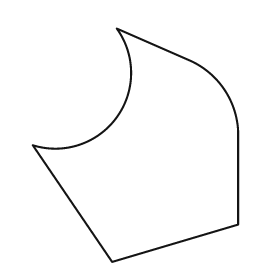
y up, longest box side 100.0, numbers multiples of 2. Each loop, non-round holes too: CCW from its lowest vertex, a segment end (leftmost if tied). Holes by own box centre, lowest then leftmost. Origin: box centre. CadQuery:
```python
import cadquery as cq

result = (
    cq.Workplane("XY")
    .moveTo(-10.0, -50.0)
    .lineTo(44.0, -34.0)
    .lineTo(44.0, 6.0)
    .threePointArc((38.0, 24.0), (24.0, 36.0))
    .lineTo(-8.0, 50.0)
    .threePointArc((-8.0, 12.0), (-44.0, 0.0))
    .close()
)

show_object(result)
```